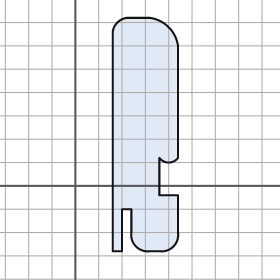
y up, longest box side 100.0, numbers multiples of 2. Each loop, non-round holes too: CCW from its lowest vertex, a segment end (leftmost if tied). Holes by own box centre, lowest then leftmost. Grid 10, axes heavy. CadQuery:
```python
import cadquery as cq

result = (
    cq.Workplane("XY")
    .moveTo(16.0, -28.0)
    .lineTo(20.0, -28.0)
    .lineTo(20.0, -10.0)
    .lineTo(24.0, -10.0)
    .lineTo(24.0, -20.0)
    .threePointArc((26.0, -26.0), (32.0, -28.0))
    .lineTo(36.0, -28.0)
    .threePointArc((42.0, -26.0), (44.0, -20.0))
    .lineTo(44.0, -4.0)
    .lineTo(36.0, -4.0)
    .lineTo(36.0, 12.0)
    .threePointArc((40.0, 10.0), (44.0, 12.0))
    .lineTo(44.0, 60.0)
    .threePointArc((40.0, 68.0), (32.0, 72.0))
    .lineTo(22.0, 72.0)
    .threePointArc((18.0, 70.0), (16.0, 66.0))
    .close()
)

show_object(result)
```